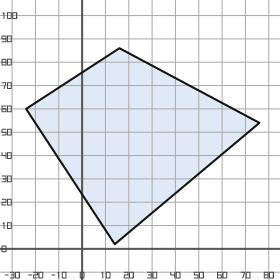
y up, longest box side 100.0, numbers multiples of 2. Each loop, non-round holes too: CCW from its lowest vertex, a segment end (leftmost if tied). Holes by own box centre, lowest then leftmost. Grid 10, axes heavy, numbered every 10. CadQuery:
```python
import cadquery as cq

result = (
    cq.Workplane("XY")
    .moveTo(14.0, 2.0)
    .lineTo(76.0, 54.0)
    .lineTo(16.0, 86.0)
    .lineTo(-24.0, 60.0)
    .close()
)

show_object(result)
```